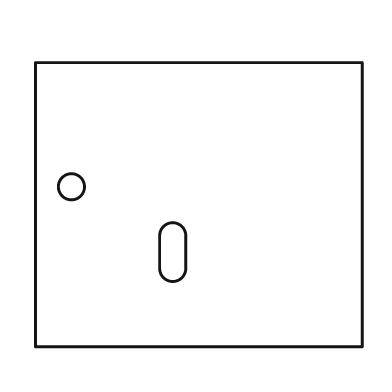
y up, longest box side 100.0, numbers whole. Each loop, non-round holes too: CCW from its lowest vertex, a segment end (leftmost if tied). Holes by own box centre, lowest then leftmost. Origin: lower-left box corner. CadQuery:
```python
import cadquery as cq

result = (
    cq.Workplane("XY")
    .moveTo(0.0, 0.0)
    .lineTo(100.0, 0.0)
    .lineTo(100.0, 87.0)
    .lineTo(0.0, 87.0)
    .close()
    .moveTo(38.0, 24.0)
    .threePointArc((42.0, 20.0), (46.0, 24.0))
    .lineTo(46.0, 34.0)
    .threePointArc((42.0, 38.0), (38.0, 34.0))
    .close()
    .moveTo(11.0, 49.0)
    .circle(4.0)
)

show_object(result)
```